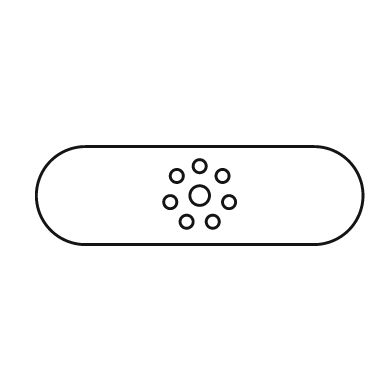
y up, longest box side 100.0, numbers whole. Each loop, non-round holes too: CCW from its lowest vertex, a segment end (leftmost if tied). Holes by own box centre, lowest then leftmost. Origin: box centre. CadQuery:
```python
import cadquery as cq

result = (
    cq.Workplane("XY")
    .moveTo(-35.0, -15.0)
    .lineTo(35.0, -15.0)
    .threePointArc((50.0, 0.0), (35.0, 15.0))
    .lineTo(-35.0, 15.0)
    .threePointArc((-50.0, 0.0), (-35.0, -15.0))
    .close()
    .moveTo(-4.0, -8.0)
    .circle(2.0)
    .moveTo(4.0, -8.0)
    .circle(2.0)
    .moveTo(-9.0, -2.0)
    .circle(2.0)
    .moveTo(9.0, -2.0)
    .circle(2.0)
    .moveTo(0.0, 0.0)
    .circle(3.0)
    .moveTo(-7.0, 6.0)
    .circle(2.0)
    .moveTo(7.0, 6.0)
    .circle(2.0)
    .moveTo(0.0, 9.0)
    .circle(2.0)
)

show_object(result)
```